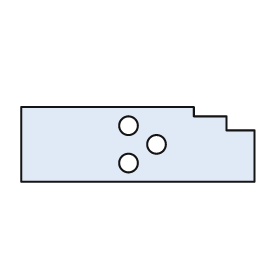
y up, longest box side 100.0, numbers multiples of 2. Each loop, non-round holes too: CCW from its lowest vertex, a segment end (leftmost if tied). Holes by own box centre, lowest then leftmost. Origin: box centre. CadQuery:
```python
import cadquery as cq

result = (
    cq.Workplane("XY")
    .moveTo(-50.0, -16.0)
    .lineTo(50.0, -16.0)
    .lineTo(50.0, 6.0)
    .lineTo(38.0, 6.0)
    .lineTo(38.0, 12.0)
    .lineTo(24.0, 12.0)
    .lineTo(24.0, 16.0)
    .lineTo(-50.0, 16.0)
    .close()
    .moveTo(-4.0, -8.0)
    .circle(4.0)
    .moveTo(8.0, 0.0)
    .circle(4.0)
    .moveTo(-4.0, 8.0)
    .circle(4.0)
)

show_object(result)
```